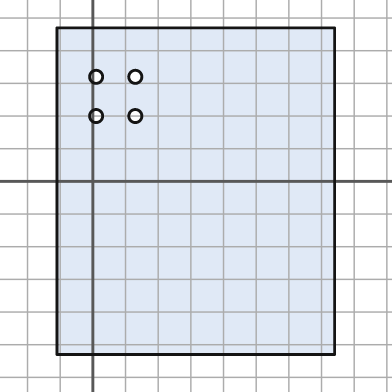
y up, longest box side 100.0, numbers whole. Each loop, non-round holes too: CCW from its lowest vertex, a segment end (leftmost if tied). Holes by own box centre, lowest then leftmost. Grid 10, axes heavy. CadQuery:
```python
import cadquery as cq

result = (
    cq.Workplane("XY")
    .moveTo(-11.0, -53.0)
    .lineTo(74.0, -53.0)
    .lineTo(74.0, 47.0)
    .lineTo(-11.0, 47.0)
    .close()
    .moveTo(1.0, 20.0)
    .circle(2.0)
    .moveTo(13.0, 20.0)
    .circle(2.0)
    .moveTo(1.0, 32.0)
    .circle(2.0)
    .moveTo(13.0, 32.0)
    .circle(2.0)
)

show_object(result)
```